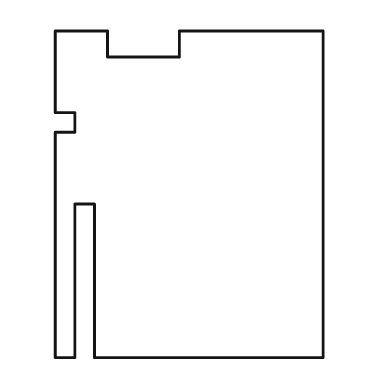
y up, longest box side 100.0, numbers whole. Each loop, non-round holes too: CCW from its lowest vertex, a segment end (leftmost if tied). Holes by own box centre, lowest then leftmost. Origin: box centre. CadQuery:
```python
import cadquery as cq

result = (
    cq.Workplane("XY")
    .moveTo(-41.0, -50.0)
    .lineTo(-35.0, -50.0)
    .lineTo(-35.0, -3.0)
    .lineTo(-29.0, -3.0)
    .lineTo(-29.0, -50.0)
    .lineTo(41.0, -50.0)
    .lineTo(41.0, 50.0)
    .lineTo(-3.0, 50.0)
    .lineTo(-3.0, 42.0)
    .lineTo(-25.0, 42.0)
    .lineTo(-25.0, 50.0)
    .lineTo(-41.0, 50.0)
    .lineTo(-41.0, 25.0)
    .lineTo(-35.0, 25.0)
    .lineTo(-35.0, 19.0)
    .lineTo(-41.0, 19.0)
    .close()
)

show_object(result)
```